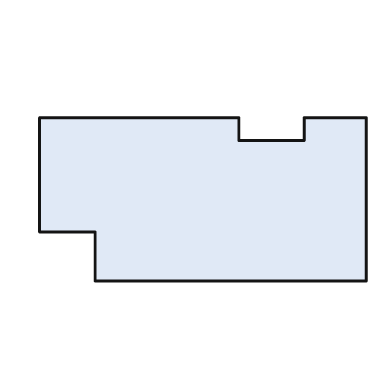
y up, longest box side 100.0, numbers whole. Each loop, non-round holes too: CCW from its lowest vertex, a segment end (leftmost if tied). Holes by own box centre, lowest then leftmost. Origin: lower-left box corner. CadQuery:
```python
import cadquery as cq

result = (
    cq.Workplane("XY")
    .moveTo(17.0, 0.0)
    .lineTo(100.0, 0.0)
    .lineTo(100.0, 50.0)
    .lineTo(81.0, 50.0)
    .lineTo(81.0, 43.0)
    .lineTo(61.0, 43.0)
    .lineTo(61.0, 50.0)
    .lineTo(0.0, 50.0)
    .lineTo(0.0, 15.0)
    .lineTo(17.0, 15.0)
    .close()
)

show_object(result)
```